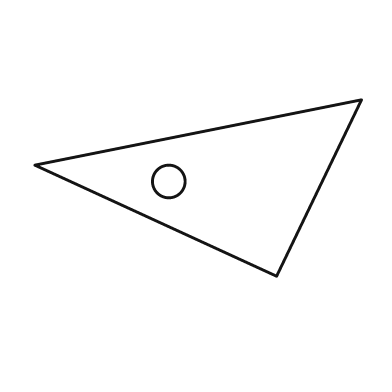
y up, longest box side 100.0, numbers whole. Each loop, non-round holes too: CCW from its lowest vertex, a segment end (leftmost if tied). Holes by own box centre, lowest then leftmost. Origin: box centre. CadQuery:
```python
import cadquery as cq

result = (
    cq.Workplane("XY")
    .moveTo(24.0, -27.0)
    .lineTo(50.0, 27.0)
    .lineTo(-50.0, 7.0)
    .close()
    .moveTo(-9.0, 2.0)
    .circle(5.0)
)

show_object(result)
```